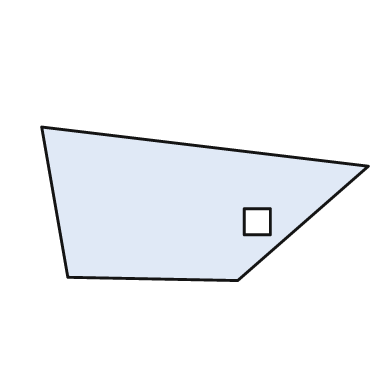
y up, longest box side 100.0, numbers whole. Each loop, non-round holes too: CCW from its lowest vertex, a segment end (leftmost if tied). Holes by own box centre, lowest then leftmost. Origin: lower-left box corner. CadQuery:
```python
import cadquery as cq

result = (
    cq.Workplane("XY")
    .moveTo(60.0, 0.0)
    .lineTo(100.0, 35.0)
    .lineTo(0.0, 47.0)
    .lineTo(8.0, 1.0)
    .close()
    .moveTo(62.0, 14.0)
    .lineTo(70.0, 14.0)
    .lineTo(70.0, 22.0)
    .lineTo(62.0, 22.0)
    .close()
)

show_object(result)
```